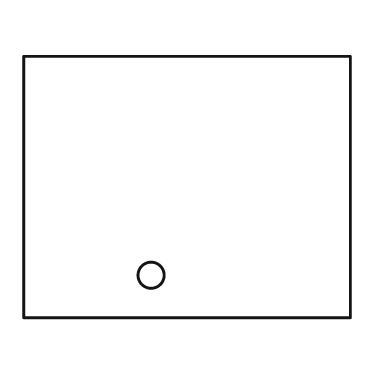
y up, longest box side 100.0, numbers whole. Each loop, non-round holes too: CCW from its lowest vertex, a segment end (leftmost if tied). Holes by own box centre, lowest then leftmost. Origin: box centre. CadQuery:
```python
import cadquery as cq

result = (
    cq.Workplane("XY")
    .moveTo(-50.0, -40.0)
    .lineTo(50.0, -40.0)
    .lineTo(50.0, 40.0)
    .lineTo(-50.0, 40.0)
    .close()
    .moveTo(-11.0, -27.0)
    .circle(4.0)
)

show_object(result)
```